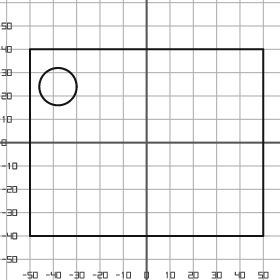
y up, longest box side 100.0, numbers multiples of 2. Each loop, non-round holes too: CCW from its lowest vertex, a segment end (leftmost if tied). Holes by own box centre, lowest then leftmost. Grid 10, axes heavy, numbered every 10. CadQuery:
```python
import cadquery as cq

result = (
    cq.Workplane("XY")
    .moveTo(-50.0, -40.0)
    .lineTo(50.0, -40.0)
    .lineTo(50.0, 40.0)
    .lineTo(-50.0, 40.0)
    .close()
    .moveTo(-38.0, 24.0)
    .circle(8.0)
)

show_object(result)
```